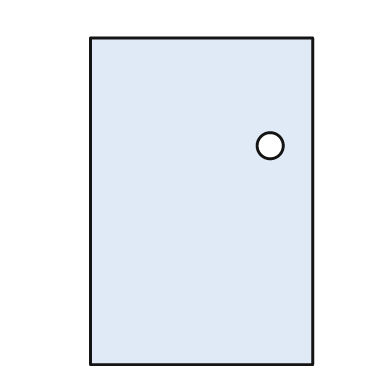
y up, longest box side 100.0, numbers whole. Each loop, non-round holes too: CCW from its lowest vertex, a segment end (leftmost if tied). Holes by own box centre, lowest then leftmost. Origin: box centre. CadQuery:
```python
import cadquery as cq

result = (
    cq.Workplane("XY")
    .moveTo(-34.0, -50.0)
    .lineTo(34.0, -50.0)
    .lineTo(34.0, 50.0)
    .lineTo(-34.0, 50.0)
    .close()
    .moveTo(21.0, 17.0)
    .circle(4.0)
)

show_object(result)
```